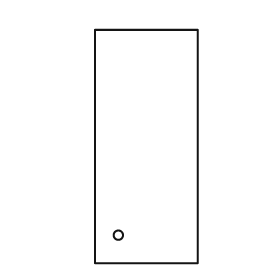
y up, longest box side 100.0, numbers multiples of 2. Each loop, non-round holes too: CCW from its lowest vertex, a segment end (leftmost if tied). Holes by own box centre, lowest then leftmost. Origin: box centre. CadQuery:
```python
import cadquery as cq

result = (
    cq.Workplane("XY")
    .moveTo(-22.0, -50.0)
    .lineTo(22.0, -50.0)
    .lineTo(22.0, 50.0)
    .lineTo(-22.0, 50.0)
    .close()
    .moveTo(-12.0, -38.0)
    .circle(2.0)
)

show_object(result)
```